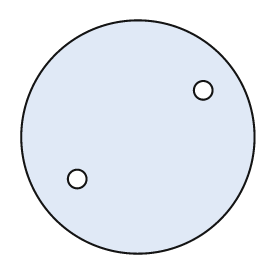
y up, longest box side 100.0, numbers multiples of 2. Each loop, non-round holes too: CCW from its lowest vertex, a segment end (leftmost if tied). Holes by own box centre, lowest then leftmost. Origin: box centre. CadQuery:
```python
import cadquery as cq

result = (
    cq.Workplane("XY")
    .moveTo(0.0, 0.0)
    .circle(50.0)
    .moveTo(-26.0, -18.0)
    .circle(4.0)
    .moveTo(28.0, 20.0)
    .circle(4.0)
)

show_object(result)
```